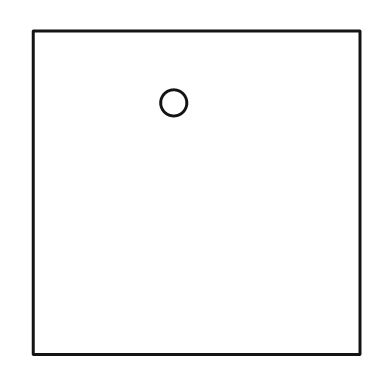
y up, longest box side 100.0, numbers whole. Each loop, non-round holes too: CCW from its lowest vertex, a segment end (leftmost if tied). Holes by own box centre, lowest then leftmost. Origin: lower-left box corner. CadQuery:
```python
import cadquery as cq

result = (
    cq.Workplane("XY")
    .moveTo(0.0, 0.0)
    .lineTo(100.0, 0.0)
    .lineTo(100.0, 99.0)
    .lineTo(0.0, 99.0)
    .close()
    .moveTo(43.0, 77.0)
    .circle(4.0)
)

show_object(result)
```